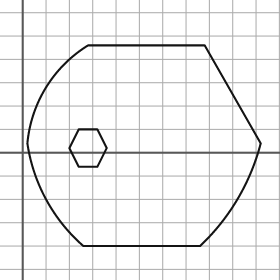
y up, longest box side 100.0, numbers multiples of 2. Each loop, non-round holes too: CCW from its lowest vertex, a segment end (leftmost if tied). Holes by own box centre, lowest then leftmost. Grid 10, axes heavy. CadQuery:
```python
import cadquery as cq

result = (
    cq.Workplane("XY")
    .moveTo(26.0, -40.0)
    .lineTo(76.0, -40.0)
    .threePointArc((92.0, -20.0), (102.0, 4.0))
    .lineTo(78.0, 46.0)
    .lineTo(28.0, 46.0)
    .threePointArc((10.0, 28.0), (2.0, 4.0))
    .threePointArc((10.0, -20.0), (26.0, -40.0))
    .close()
    .moveTo(24.0, -6.0)
    .lineTo(32.0, -6.0)
    .lineTo(36.0, 2.0)
    .lineTo(32.0, 10.0)
    .lineTo(24.0, 10.0)
    .lineTo(20.0, 2.0)
    .close()
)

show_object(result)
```